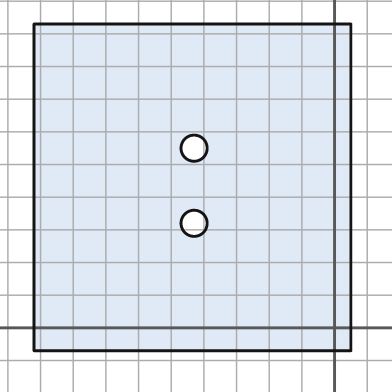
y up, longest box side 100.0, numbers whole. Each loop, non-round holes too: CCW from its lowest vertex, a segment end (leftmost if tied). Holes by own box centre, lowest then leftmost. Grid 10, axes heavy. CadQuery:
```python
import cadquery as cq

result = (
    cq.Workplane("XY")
    .moveTo(-92.0, -7.0)
    .lineTo(5.0, -7.0)
    .lineTo(5.0, 93.0)
    .lineTo(-92.0, 93.0)
    .close()
    .moveTo(-43.0, 32.0)
    .circle(4.0)
    .moveTo(-43.0, 55.0)
    .circle(4.0)
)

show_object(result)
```